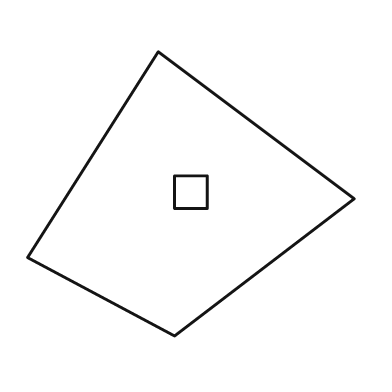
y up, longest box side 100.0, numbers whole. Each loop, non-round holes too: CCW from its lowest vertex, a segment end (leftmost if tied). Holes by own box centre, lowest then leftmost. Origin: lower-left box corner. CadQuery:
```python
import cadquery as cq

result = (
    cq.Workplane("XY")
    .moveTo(45.0, 0.0)
    .lineTo(100.0, 42.0)
    .lineTo(40.0, 87.0)
    .lineTo(0.0, 24.0)
    .close()
    .moveTo(45.0, 39.0)
    .lineTo(55.0, 39.0)
    .lineTo(55.0, 49.0)
    .lineTo(45.0, 49.0)
    .close()
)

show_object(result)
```